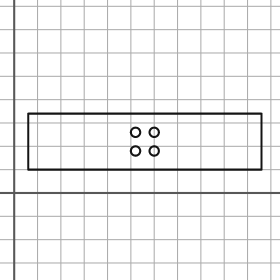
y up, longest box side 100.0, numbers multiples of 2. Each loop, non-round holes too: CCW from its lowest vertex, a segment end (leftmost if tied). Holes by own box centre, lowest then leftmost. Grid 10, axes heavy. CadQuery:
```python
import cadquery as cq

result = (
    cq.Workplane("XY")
    .moveTo(6.0, 10.0)
    .lineTo(106.0, 10.0)
    .lineTo(106.0, 34.0)
    .lineTo(6.0, 34.0)
    .close()
    .moveTo(52.0, 18.0)
    .circle(2.0)
    .moveTo(60.0, 18.0)
    .circle(2.0)
    .moveTo(52.0, 26.0)
    .circle(2.0)
    .moveTo(60.0, 26.0)
    .circle(2.0)
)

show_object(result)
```